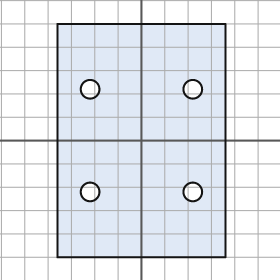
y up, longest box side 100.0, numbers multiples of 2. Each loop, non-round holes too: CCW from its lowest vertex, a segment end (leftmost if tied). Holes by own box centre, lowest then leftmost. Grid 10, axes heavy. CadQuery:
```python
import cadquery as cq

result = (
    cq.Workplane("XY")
    .moveTo(-36.0, -50.0)
    .lineTo(36.0, -50.0)
    .lineTo(36.0, 50.0)
    .lineTo(-36.0, 50.0)
    .close()
    .moveTo(-22.0, -22.0)
    .circle(4.0)
    .moveTo(22.0, -22.0)
    .circle(4.0)
    .moveTo(-22.0, 22.0)
    .circle(4.0)
    .moveTo(22.0, 22.0)
    .circle(4.0)
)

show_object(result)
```